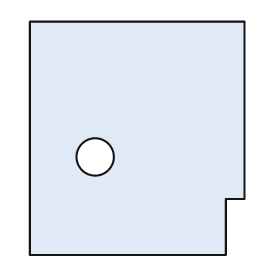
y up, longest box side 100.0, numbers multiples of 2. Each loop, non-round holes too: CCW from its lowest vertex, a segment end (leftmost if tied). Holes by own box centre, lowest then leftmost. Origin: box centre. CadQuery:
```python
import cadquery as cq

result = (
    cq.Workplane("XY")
    .moveTo(-46.0, -50.0)
    .lineTo(38.0, -50.0)
    .lineTo(38.0, -26.0)
    .lineTo(46.0, -26.0)
    .lineTo(46.0, 50.0)
    .lineTo(-46.0, 50.0)
    .close()
    .moveTo(-18.0, -8.0)
    .circle(8.0)
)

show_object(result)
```